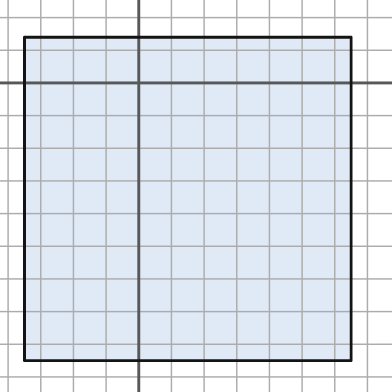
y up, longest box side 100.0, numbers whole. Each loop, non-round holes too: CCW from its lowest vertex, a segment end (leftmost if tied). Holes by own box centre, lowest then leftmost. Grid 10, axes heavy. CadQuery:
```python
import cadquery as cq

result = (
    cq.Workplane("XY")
    .moveTo(-35.0, -85.0)
    .lineTo(65.0, -85.0)
    .lineTo(65.0, 14.0)
    .lineTo(-35.0, 14.0)
    .close()
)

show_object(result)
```